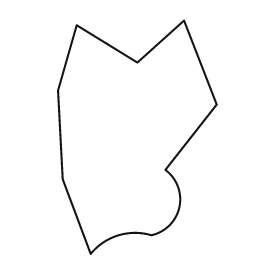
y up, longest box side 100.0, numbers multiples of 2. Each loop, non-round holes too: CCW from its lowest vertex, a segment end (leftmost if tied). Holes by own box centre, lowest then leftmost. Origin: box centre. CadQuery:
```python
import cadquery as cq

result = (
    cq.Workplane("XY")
    .moveTo(-20.0, -50.0)
    .threePointArc((-8.0, -42.0), (6.0, -42.0))
    .threePointArc((18.0, -30.0), (12.0, -14.0))
    .lineTo(34.0, 14.0)
    .lineTo(20.0, 50.0)
    .lineTo(0.0, 32.0)
    .lineTo(-26.0, 48.0)
    .lineTo(-34.0, 20.0)
    .lineTo(-32.0, -18.0)
    .close()
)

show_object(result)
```